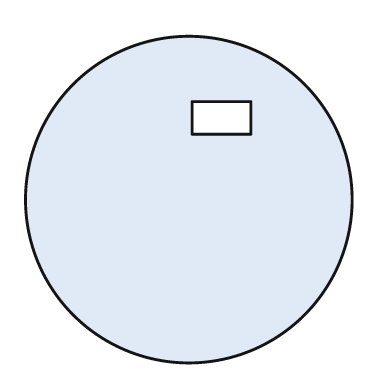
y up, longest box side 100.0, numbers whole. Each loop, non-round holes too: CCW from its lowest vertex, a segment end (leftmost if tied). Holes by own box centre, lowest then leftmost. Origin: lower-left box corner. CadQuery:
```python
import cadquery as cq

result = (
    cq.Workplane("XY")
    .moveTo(50.0, 50.0)
    .circle(50.0)
    .moveTo(51.0, 70.0)
    .lineTo(69.0, 70.0)
    .lineTo(69.0, 80.0)
    .lineTo(51.0, 80.0)
    .close()
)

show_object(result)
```